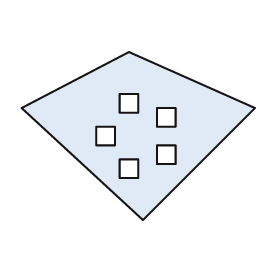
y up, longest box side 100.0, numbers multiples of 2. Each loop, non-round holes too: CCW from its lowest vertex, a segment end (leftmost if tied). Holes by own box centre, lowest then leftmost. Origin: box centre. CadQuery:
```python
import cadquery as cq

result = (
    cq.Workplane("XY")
    .moveTo(2.0, -36.0)
    .lineTo(50.0, 12.0)
    .lineTo(-4.0, 36.0)
    .lineTo(-50.0, 12.0)
    .close()
    .moveTo(-8.0, -18.0)
    .lineTo(0.0, -18.0)
    .lineTo(0.0, -10.0)
    .lineTo(-8.0, -10.0)
    .close()
    .moveTo(8.0, -12.0)
    .lineTo(16.0, -12.0)
    .lineTo(16.0, -4.0)
    .lineTo(8.0, -4.0)
    .close()
    .moveTo(-18.0, -4.0)
    .lineTo(-10.0, -4.0)
    .lineTo(-10.0, 4.0)
    .lineTo(-18.0, 4.0)
    .close()
    .moveTo(8.0, 4.0)
    .lineTo(16.0, 4.0)
    .lineTo(16.0, 12.0)
    .lineTo(8.0, 12.0)
    .close()
    .moveTo(-8.0, 10.0)
    .lineTo(0.0, 10.0)
    .lineTo(0.0, 18.0)
    .lineTo(-8.0, 18.0)
    .close()
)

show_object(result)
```